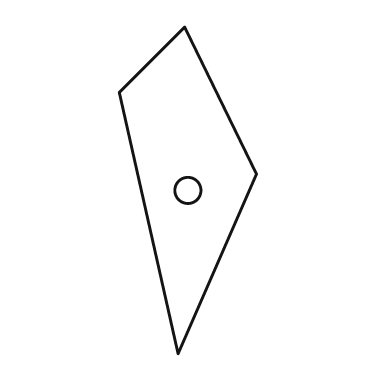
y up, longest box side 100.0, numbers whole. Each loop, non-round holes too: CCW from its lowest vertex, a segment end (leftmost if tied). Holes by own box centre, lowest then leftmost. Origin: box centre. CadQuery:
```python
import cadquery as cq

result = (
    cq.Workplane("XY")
    .moveTo(-3.0, -50.0)
    .lineTo(21.0, 5.0)
    .lineTo(-1.0, 50.0)
    .lineTo(-21.0, 30.0)
    .close()
    .moveTo(0.0, 0.0)
    .circle(4.0)
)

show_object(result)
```